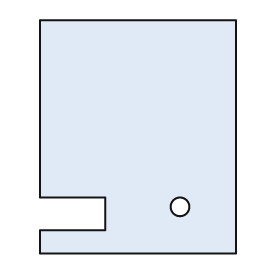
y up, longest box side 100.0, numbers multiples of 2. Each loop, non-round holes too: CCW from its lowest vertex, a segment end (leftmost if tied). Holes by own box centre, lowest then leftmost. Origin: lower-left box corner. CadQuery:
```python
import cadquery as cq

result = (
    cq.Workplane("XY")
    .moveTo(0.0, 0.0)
    .lineTo(84.0, 0.0)
    .lineTo(84.0, 100.0)
    .lineTo(0.0, 100.0)
    .lineTo(0.0, 24.0)
    .lineTo(28.0, 24.0)
    .lineTo(28.0, 10.0)
    .lineTo(0.0, 10.0)
    .close()
    .moveTo(60.0, 20.0)
    .circle(4.0)
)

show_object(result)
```